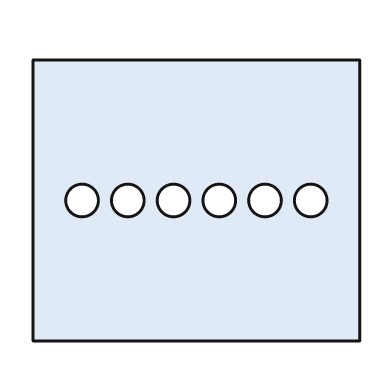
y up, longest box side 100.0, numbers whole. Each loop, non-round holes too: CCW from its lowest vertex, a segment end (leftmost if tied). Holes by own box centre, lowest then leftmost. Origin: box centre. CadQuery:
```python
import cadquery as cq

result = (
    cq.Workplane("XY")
    .moveTo(-50.0, -43.0)
    .lineTo(50.0, -43.0)
    .lineTo(50.0, 43.0)
    .lineTo(-50.0, 43.0)
    .close()
    .moveTo(-35.0, 0.0)
    .circle(5.0)
    .moveTo(-21.0, 0.0)
    .circle(5.0)
    .moveTo(-7.0, 0.0)
    .circle(5.0)
    .moveTo(7.0, 0.0)
    .circle(5.0)
    .moveTo(21.0, 0.0)
    .circle(5.0)
    .moveTo(35.0, 0.0)
    .circle(5.0)
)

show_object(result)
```